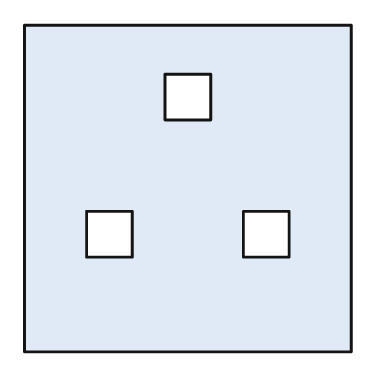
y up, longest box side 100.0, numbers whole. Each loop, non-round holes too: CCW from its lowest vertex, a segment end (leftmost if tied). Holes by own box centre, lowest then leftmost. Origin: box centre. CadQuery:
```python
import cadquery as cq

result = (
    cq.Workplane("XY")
    .moveTo(-50.0, -50.0)
    .lineTo(50.0, -50.0)
    .lineTo(50.0, 50.0)
    .lineTo(-50.0, 50.0)
    .close()
    .moveTo(-31.0, -21.0)
    .lineTo(-17.0, -21.0)
    .lineTo(-17.0, -7.0)
    .lineTo(-31.0, -7.0)
    .close()
    .moveTo(17.0, -21.0)
    .lineTo(31.0, -21.0)
    .lineTo(31.0, -7.0)
    .lineTo(17.0, -7.0)
    .close()
    .moveTo(-7.0, 21.0)
    .lineTo(7.0, 21.0)
    .lineTo(7.0, 35.0)
    .lineTo(-7.0, 35.0)
    .close()
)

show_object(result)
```